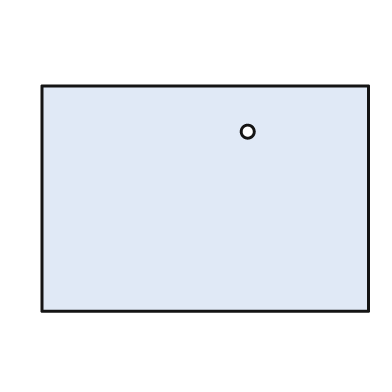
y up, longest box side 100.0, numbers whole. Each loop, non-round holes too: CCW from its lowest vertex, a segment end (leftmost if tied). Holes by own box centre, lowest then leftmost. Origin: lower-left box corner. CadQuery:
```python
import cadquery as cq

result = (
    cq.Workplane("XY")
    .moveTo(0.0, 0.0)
    .lineTo(100.0, 0.0)
    .lineTo(100.0, 69.0)
    .lineTo(0.0, 69.0)
    .close()
    .moveTo(63.0, 55.0)
    .circle(2.0)
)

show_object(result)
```